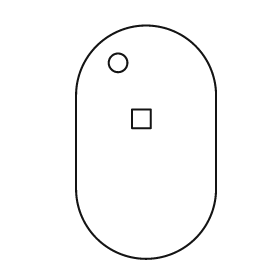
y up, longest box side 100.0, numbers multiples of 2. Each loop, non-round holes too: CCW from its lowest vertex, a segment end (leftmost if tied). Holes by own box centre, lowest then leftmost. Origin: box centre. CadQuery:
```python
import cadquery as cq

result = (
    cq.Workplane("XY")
    .moveTo(-30.0, -20.0)
    .threePointArc((0.0, -50.0), (30.0, -20.0))
    .lineTo(30.0, 20.0)
    .threePointArc((0.0, 50.0), (-30.0, 20.0))
    .close()
    .moveTo(-6.0, 6.0)
    .lineTo(2.0, 6.0)
    .lineTo(2.0, 14.0)
    .lineTo(-6.0, 14.0)
    .close()
    .moveTo(-12.0, 34.0)
    .circle(4.0)
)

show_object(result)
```